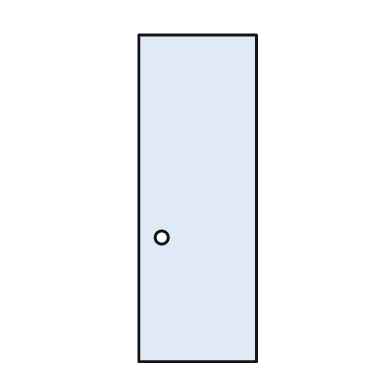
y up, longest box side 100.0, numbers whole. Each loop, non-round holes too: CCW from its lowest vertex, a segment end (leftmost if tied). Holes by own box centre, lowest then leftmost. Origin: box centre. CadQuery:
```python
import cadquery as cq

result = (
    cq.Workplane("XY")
    .moveTo(-18.0, -50.0)
    .lineTo(18.0, -50.0)
    .lineTo(18.0, 50.0)
    .lineTo(-18.0, 50.0)
    .close()
    .moveTo(-11.0, -12.0)
    .circle(2.0)
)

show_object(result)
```